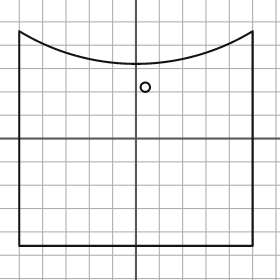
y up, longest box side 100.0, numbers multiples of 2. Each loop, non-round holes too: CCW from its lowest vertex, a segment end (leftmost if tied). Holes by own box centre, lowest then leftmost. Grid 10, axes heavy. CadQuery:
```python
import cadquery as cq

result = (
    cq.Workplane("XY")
    .moveTo(-50.0, -46.0)
    .lineTo(50.0, -46.0)
    .lineTo(50.0, 46.0)
    .threePointArc((0.0, 32.0), (-50.0, 46.0))
    .close()
    .moveTo(4.0, 22.0)
    .circle(2.0)
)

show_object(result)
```